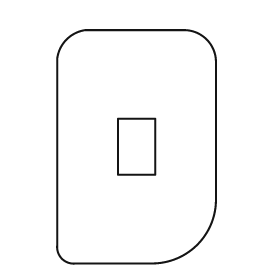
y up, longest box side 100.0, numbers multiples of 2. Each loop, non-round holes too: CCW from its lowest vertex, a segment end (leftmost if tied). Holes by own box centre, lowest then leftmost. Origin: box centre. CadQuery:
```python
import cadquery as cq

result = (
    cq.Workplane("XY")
    .moveTo(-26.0, -50.0)
    .lineTo(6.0, -50.0)
    .threePointArc((26.0, -42.0), (34.0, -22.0))
    .lineTo(34.0, 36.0)
    .threePointArc((30.0, 46.0), (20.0, 50.0))
    .lineTo(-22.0, 50.0)
    .threePointArc((-30.0, 46.0), (-34.0, 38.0))
    .lineTo(-34.0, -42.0)
    .threePointArc((-32.0, -48.0), (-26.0, -50.0))
    .close()
    .moveTo(-8.0, -12.0)
    .lineTo(8.0, -12.0)
    .lineTo(8.0, 12.0)
    .lineTo(-8.0, 12.0)
    .close()
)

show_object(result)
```